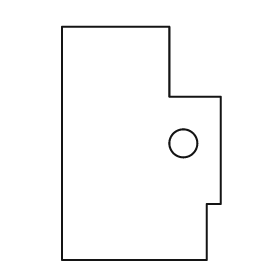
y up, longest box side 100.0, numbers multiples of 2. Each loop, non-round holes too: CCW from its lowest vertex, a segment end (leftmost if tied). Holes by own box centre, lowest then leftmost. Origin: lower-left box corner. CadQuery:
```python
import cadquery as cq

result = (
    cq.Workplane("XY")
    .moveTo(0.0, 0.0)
    .lineTo(62.0, 0.0)
    .lineTo(62.0, 24.0)
    .lineTo(68.0, 24.0)
    .lineTo(68.0, 70.0)
    .lineTo(46.0, 70.0)
    .lineTo(46.0, 100.0)
    .lineTo(0.0, 100.0)
    .close()
    .moveTo(52.0, 50.0)
    .circle(6.0)
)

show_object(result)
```